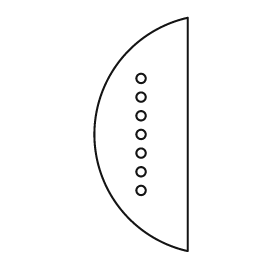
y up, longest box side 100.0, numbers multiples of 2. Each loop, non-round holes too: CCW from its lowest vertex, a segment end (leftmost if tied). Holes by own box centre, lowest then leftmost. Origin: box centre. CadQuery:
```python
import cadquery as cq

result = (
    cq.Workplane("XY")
    .moveTo(20.0, -50.0)
    .lineTo(20.0, 50.0)
    .threePointArc((-20.0, 0.0), (20.0, -50.0))
    .close()
    .moveTo(0.0, -24.0)
    .circle(2.0)
    .moveTo(0.0, -16.0)
    .circle(2.0)
    .moveTo(0.0, -8.0)
    .circle(2.0)
    .moveTo(0.0, 0.0)
    .circle(2.0)
    .moveTo(0.0, 8.0)
    .circle(2.0)
    .moveTo(0.0, 16.0)
    .circle(2.0)
    .moveTo(0.0, 24.0)
    .circle(2.0)
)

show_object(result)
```